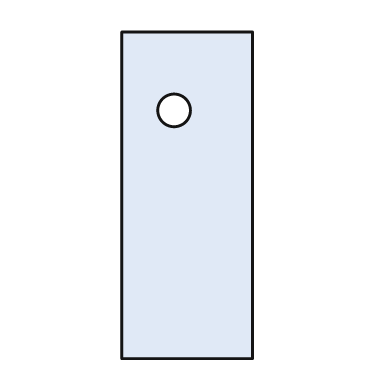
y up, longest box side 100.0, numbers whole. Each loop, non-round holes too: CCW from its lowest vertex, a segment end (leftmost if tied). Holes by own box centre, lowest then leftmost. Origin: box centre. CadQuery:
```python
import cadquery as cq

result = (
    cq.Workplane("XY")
    .moveTo(-20.0, -50.0)
    .lineTo(20.0, -50.0)
    .lineTo(20.0, 50.0)
    .lineTo(-20.0, 50.0)
    .close()
    .moveTo(-4.0, 26.0)
    .circle(5.0)
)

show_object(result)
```